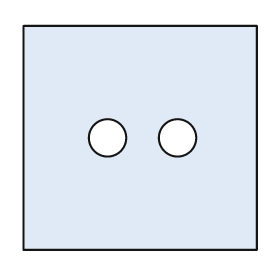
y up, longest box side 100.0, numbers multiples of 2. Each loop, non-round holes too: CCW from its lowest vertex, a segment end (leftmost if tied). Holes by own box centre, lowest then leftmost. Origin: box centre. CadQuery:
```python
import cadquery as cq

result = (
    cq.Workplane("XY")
    .moveTo(-50.0, -48.0)
    .lineTo(50.0, -48.0)
    .lineTo(50.0, 48.0)
    .lineTo(-50.0, 48.0)
    .close()
    .moveTo(-14.0, 0.0)
    .circle(8.0)
    .moveTo(16.0, 0.0)
    .circle(8.0)
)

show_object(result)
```